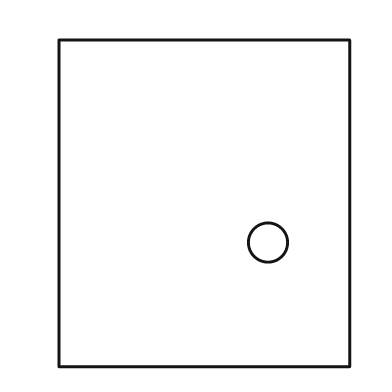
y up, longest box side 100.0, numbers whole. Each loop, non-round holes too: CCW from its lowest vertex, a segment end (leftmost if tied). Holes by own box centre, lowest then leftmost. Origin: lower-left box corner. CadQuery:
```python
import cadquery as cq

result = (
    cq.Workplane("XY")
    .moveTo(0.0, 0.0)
    .lineTo(89.0, 0.0)
    .lineTo(89.0, 100.0)
    .lineTo(0.0, 100.0)
    .close()
    .moveTo(64.0, 38.0)
    .circle(6.0)
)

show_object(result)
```